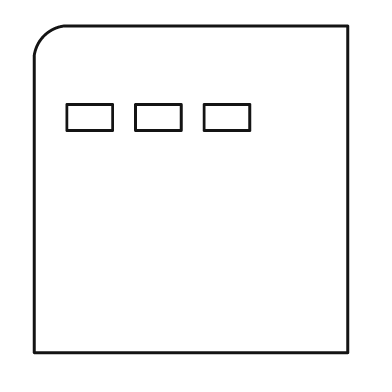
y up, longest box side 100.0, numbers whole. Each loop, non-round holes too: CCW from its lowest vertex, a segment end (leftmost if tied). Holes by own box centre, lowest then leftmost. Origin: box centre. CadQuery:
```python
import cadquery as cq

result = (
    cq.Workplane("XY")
    .moveTo(-48.0, -50.0)
    .lineTo(48.0, -50.0)
    .lineTo(48.0, 50.0)
    .lineTo(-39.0, 50.0)
    .threePointArc((-45.0, 47.0), (-48.0, 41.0))
    .close()
    .moveTo(-38.0, 18.0)
    .lineTo(-24.0, 18.0)
    .lineTo(-24.0, 26.0)
    .lineTo(-38.0, 26.0)
    .close()
    .moveTo(-17.0, 18.0)
    .lineTo(-3.0, 18.0)
    .lineTo(-3.0, 26.0)
    .lineTo(-17.0, 26.0)
    .close()
    .moveTo(4.0, 18.0)
    .lineTo(18.0, 18.0)
    .lineTo(18.0, 26.0)
    .lineTo(4.0, 26.0)
    .close()
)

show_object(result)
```